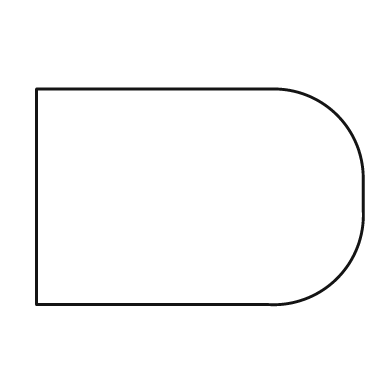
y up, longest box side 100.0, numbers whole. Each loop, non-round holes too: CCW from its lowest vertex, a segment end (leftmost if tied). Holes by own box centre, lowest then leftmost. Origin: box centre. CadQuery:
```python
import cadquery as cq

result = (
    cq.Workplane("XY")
    .moveTo(-50.0, -33.0)
    .lineTo(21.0, -33.0)
    .threePointArc((42.0, -25.0), (50.0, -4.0))
    .lineTo(50.0, 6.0)
    .threePointArc((42.0, 25.0), (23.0, 33.0))
    .lineTo(-50.0, 33.0)
    .close()
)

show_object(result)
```